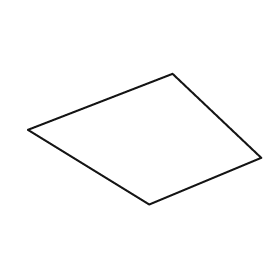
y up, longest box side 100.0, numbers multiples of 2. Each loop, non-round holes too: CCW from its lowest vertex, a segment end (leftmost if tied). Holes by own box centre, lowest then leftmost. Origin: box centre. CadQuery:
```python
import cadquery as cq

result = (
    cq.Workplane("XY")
    .moveTo(2.0, -28.0)
    .lineTo(50.0, -8.0)
    .lineTo(12.0, 28.0)
    .lineTo(-50.0, 4.0)
    .close()
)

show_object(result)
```